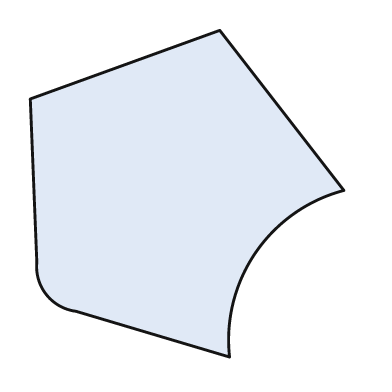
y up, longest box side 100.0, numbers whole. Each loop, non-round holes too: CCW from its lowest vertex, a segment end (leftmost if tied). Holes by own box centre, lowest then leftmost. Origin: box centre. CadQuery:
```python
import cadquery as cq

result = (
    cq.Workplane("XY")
    .moveTo(13.0, -50.0)
    .threePointArc((21.0, -18.0), (48.0, 1.0))
    .lineTo(10.0, 50.0)
    .lineTo(-48.0, 29.0)
    .lineTo(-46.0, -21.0)
    .threePointArc((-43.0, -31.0), (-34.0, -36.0))
    .close()
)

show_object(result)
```